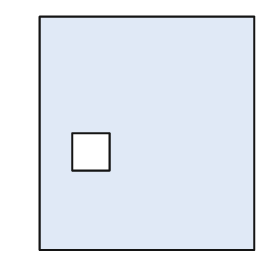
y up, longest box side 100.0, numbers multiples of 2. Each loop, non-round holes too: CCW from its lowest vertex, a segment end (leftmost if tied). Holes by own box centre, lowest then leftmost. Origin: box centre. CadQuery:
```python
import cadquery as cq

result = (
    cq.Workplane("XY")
    .moveTo(-46.0, -50.0)
    .lineTo(46.0, -50.0)
    .lineTo(46.0, 50.0)
    .lineTo(-46.0, 50.0)
    .close()
    .moveTo(-32.0, -16.0)
    .lineTo(-16.0, -16.0)
    .lineTo(-16.0, 0.0)
    .lineTo(-32.0, 0.0)
    .close()
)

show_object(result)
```